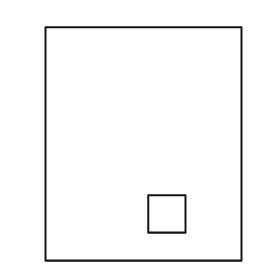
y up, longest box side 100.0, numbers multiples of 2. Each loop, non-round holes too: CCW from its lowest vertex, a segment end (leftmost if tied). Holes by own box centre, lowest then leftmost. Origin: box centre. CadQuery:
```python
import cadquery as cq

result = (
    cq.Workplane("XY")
    .moveTo(-42.0, -50.0)
    .lineTo(42.0, -50.0)
    .lineTo(42.0, 50.0)
    .lineTo(-42.0, 50.0)
    .close()
    .moveTo(2.0, -38.0)
    .lineTo(18.0, -38.0)
    .lineTo(18.0, -22.0)
    .lineTo(2.0, -22.0)
    .close()
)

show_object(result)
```